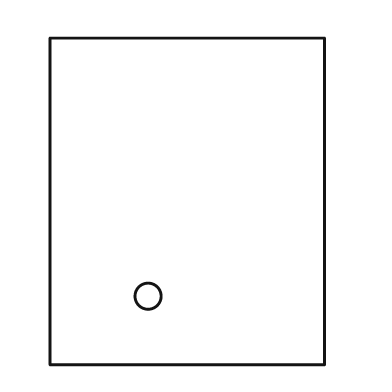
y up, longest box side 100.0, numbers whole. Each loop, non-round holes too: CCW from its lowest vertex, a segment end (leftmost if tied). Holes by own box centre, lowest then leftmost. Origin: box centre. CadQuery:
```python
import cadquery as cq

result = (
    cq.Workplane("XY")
    .moveTo(-42.0, -50.0)
    .lineTo(42.0, -50.0)
    .lineTo(42.0, 50.0)
    .lineTo(-42.0, 50.0)
    .close()
    .moveTo(-12.0, -29.0)
    .circle(4.0)
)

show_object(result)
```